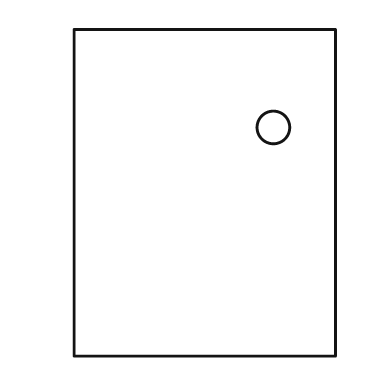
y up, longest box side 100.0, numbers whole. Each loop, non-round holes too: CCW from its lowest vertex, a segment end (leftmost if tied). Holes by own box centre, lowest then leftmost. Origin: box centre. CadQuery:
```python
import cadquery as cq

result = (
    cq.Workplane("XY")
    .moveTo(-40.0, -50.0)
    .lineTo(40.0, -50.0)
    .lineTo(40.0, 50.0)
    .lineTo(-40.0, 50.0)
    .close()
    .moveTo(21.0, 20.0)
    .circle(5.0)
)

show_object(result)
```